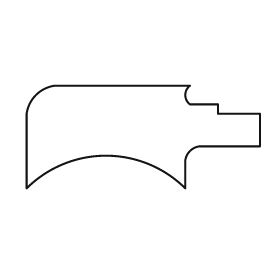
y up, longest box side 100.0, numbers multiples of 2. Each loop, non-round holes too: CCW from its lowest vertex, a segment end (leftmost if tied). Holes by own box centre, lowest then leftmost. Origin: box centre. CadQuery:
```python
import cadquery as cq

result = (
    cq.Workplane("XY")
    .moveTo(-50.0, -22.0)
    .threePointArc((-16.0, -8.0), (18.0, -22.0))
    .lineTo(18.0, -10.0)
    .threePointArc((20.0, -6.0), (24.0, -4.0))
    .lineTo(50.0, -4.0)
    .lineTo(50.0, 10.0)
    .lineTo(32.0, 10.0)
    .lineTo(32.0, 14.0)
    .lineTo(20.0, 14.0)
    .threePointArc((18.0, 18.0), (20.0, 22.0))
    .lineTo(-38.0, 22.0)
    .threePointArc((-46.0, 18.0), (-50.0, 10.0))
    .close()
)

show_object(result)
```